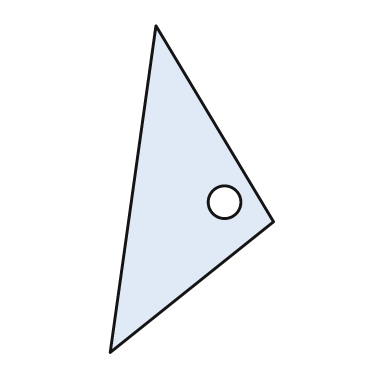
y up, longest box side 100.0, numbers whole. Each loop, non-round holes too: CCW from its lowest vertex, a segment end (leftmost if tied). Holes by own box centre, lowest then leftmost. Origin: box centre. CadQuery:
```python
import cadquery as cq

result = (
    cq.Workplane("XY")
    .moveTo(-25.0, -50.0)
    .lineTo(25.0, -10.0)
    .lineTo(-11.0, 50.0)
    .close()
    .moveTo(10.0, -4.0)
    .circle(5.0)
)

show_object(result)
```